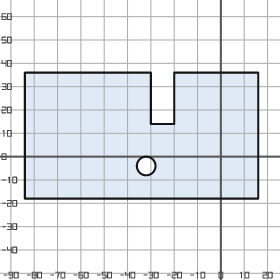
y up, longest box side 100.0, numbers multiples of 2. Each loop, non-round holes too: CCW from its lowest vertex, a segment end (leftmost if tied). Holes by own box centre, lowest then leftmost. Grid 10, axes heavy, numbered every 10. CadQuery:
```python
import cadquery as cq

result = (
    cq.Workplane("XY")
    .moveTo(-84.0, -18.0)
    .lineTo(16.0, -18.0)
    .lineTo(16.0, 36.0)
    .lineTo(-20.0, 36.0)
    .lineTo(-20.0, 14.0)
    .lineTo(-30.0, 14.0)
    .lineTo(-30.0, 36.0)
    .lineTo(-84.0, 36.0)
    .close()
    .moveTo(-32.0, -4.0)
    .circle(4.0)
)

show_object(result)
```